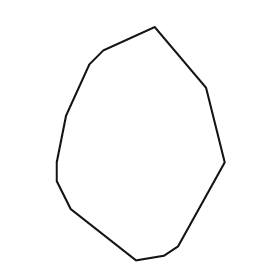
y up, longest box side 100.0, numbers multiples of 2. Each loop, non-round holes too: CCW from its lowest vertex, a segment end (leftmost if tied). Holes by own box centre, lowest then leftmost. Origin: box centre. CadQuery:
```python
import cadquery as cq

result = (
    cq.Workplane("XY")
    .moveTo(-2.0, -50.0)
    .lineTo(10.0, -48.0)
    .lineTo(16.0, -44.0)
    .lineTo(36.0, -8.0)
    .lineTo(28.0, 24.0)
    .lineTo(6.0, 50.0)
    .lineTo(-16.0, 40.0)
    .lineTo(-22.0, 34.0)
    .lineTo(-32.0, 12.0)
    .lineTo(-36.0, -8.0)
    .lineTo(-36.0, -16.0)
    .lineTo(-30.0, -28.0)
    .close()
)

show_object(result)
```